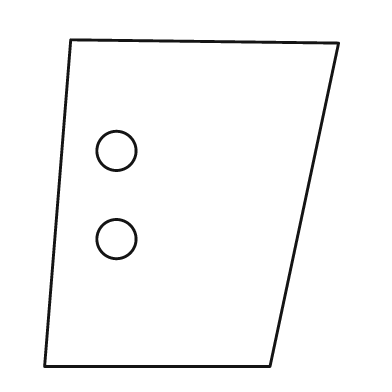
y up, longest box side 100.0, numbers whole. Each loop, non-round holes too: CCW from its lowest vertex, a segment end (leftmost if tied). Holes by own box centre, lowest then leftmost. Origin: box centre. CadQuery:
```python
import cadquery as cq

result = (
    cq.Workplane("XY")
    .moveTo(-45.0, -50.0)
    .lineTo(24.0, -50.0)
    .lineTo(45.0, 49.0)
    .lineTo(-37.0, 50.0)
    .close()
    .moveTo(-23.0, -11.0)
    .circle(6.0)
    .moveTo(-23.0, 16.0)
    .circle(6.0)
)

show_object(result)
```